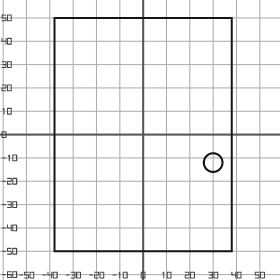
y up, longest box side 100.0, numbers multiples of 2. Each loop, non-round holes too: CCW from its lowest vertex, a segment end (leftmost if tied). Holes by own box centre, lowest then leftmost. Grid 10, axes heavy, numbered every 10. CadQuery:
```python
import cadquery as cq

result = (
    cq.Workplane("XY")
    .moveTo(-38.0, -50.0)
    .lineTo(38.0, -50.0)
    .lineTo(38.0, 50.0)
    .lineTo(-38.0, 50.0)
    .close()
    .moveTo(30.0, -12.0)
    .circle(4.0)
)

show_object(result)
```